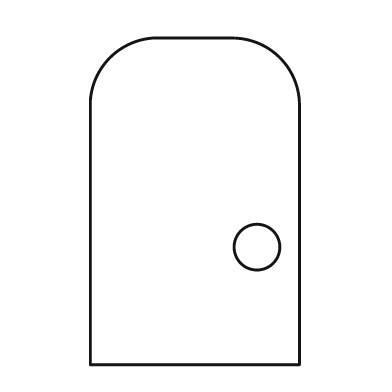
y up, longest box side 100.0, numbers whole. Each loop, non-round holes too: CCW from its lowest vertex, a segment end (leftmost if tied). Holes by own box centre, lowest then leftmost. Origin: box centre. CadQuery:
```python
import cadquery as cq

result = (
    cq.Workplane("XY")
    .moveTo(-32.0, -50.0)
    .lineTo(32.0, -50.0)
    .lineTo(32.0, 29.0)
    .threePointArc((26.0, 44.0), (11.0, 50.0))
    .lineTo(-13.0, 50.0)
    .threePointArc((-26.0, 44.0), (-32.0, 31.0))
    .close()
    .moveTo(19.0, -14.0)
    .circle(7.0)
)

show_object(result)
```